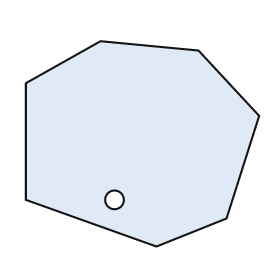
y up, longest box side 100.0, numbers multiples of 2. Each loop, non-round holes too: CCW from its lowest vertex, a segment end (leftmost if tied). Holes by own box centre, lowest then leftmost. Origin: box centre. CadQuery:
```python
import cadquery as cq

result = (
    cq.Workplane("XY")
    .moveTo(6.0, -44.0)
    .lineTo(36.0, -32.0)
    .lineTo(50.0, 12.0)
    .lineTo(24.0, 40.0)
    .lineTo(-18.0, 44.0)
    .lineTo(-50.0, 26.0)
    .lineTo(-50.0, -24.0)
    .close()
    .moveTo(-12.0, -24.0)
    .circle(4.0)
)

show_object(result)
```